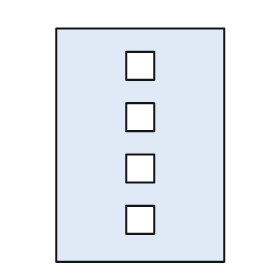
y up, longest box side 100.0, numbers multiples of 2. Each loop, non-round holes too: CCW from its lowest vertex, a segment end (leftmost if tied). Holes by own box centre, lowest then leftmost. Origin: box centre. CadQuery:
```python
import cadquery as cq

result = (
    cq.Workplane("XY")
    .moveTo(-36.0, -50.0)
    .lineTo(36.0, -50.0)
    .lineTo(36.0, 50.0)
    .lineTo(-36.0, 50.0)
    .close()
    .moveTo(-6.0, -38.0)
    .lineTo(6.0, -38.0)
    .lineTo(6.0, -26.0)
    .lineTo(-6.0, -26.0)
    .close()
    .moveTo(-6.0, -16.0)
    .lineTo(6.0, -16.0)
    .lineTo(6.0, -4.0)
    .lineTo(-6.0, -4.0)
    .close()
    .moveTo(-6.0, 6.0)
    .lineTo(6.0, 6.0)
    .lineTo(6.0, 18.0)
    .lineTo(-6.0, 18.0)
    .close()
    .moveTo(-6.0, 28.0)
    .lineTo(6.0, 28.0)
    .lineTo(6.0, 40.0)
    .lineTo(-6.0, 40.0)
    .close()
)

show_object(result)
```